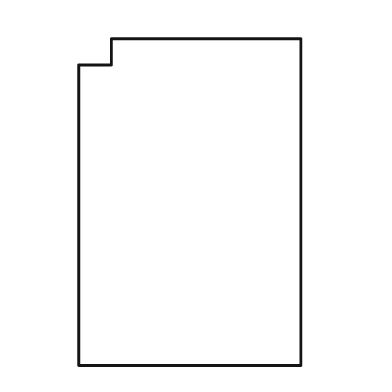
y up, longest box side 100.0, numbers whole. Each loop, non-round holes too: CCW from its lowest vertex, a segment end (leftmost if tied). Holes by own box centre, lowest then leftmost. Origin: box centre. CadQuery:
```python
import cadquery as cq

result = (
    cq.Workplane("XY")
    .moveTo(-34.0, -50.0)
    .lineTo(34.0, -50.0)
    .lineTo(34.0, 50.0)
    .lineTo(-24.0, 50.0)
    .lineTo(-24.0, 42.0)
    .lineTo(-34.0, 42.0)
    .close()
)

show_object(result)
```